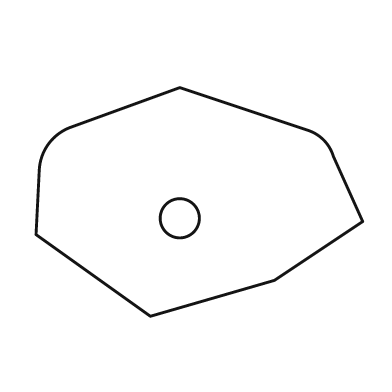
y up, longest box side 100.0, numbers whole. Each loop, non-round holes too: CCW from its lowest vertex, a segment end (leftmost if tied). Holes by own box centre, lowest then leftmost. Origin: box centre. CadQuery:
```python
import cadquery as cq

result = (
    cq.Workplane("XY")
    .moveTo(-15.0, -35.0)
    .lineTo(23.0, -24.0)
    .lineTo(50.0, -6.0)
    .lineTo(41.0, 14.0)
    .threePointArc((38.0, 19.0), (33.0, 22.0))
    .lineTo(-6.0, 35.0)
    .lineTo(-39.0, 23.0)
    .threePointArc((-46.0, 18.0), (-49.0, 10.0))
    .lineTo(-50.0, -10.0)
    .close()
    .moveTo(-6.0, -5.0)
    .circle(6.0)
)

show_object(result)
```